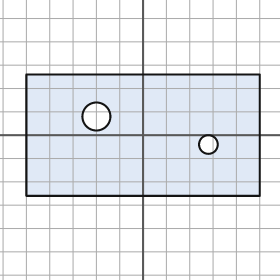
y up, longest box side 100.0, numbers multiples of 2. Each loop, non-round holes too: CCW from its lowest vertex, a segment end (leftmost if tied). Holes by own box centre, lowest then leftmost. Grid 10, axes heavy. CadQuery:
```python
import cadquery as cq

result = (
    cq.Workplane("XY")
    .moveTo(-50.0, -26.0)
    .lineTo(50.0, -26.0)
    .lineTo(50.0, 26.0)
    .lineTo(-50.0, 26.0)
    .close()
    .moveTo(28.0, -4.0)
    .circle(4.0)
    .moveTo(-20.0, 8.0)
    .circle(6.0)
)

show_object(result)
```